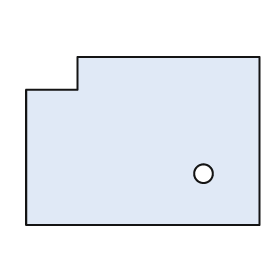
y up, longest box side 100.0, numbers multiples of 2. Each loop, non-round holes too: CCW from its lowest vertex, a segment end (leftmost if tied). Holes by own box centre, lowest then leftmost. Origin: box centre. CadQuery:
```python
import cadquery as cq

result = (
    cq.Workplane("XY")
    .moveTo(-50.0, -36.0)
    .lineTo(50.0, -36.0)
    .lineTo(50.0, 36.0)
    .lineTo(-28.0, 36.0)
    .lineTo(-28.0, 22.0)
    .lineTo(-50.0, 22.0)
    .close()
    .moveTo(26.0, -14.0)
    .circle(4.0)
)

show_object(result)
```